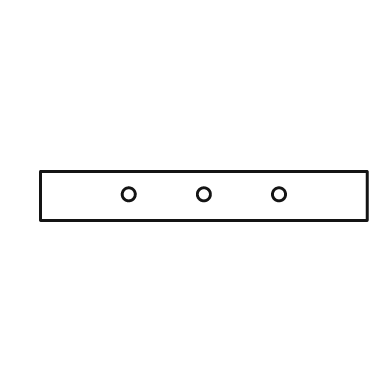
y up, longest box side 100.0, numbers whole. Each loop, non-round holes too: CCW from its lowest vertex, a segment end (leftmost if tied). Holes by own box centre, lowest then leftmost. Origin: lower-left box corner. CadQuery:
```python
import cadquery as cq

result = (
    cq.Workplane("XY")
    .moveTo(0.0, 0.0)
    .lineTo(100.0, 0.0)
    .lineTo(100.0, 15.0)
    .lineTo(0.0, 15.0)
    .close()
    .moveTo(27.0, 8.0)
    .circle(2.0)
    .moveTo(50.0, 8.0)
    .circle(2.0)
    .moveTo(73.0, 8.0)
    .circle(2.0)
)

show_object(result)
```